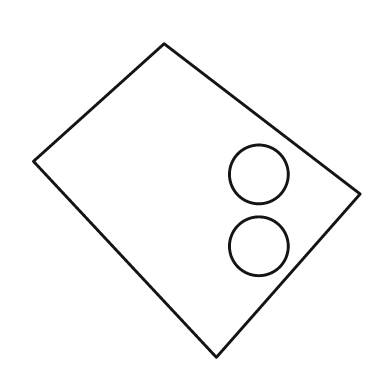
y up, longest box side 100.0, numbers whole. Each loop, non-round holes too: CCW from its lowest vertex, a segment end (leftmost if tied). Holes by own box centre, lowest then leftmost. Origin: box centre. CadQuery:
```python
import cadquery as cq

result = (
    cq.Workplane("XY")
    .moveTo(6.0, -48.0)
    .lineTo(50.0, 2.0)
    .lineTo(-10.0, 48.0)
    .lineTo(-50.0, 12.0)
    .close()
    .moveTo(19.0, -14.0)
    .circle(9.0)
    .moveTo(19.0, 8.0)
    .circle(9.0)
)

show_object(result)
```